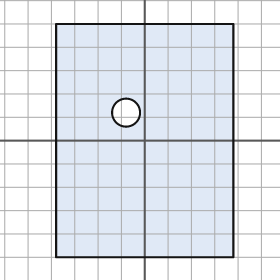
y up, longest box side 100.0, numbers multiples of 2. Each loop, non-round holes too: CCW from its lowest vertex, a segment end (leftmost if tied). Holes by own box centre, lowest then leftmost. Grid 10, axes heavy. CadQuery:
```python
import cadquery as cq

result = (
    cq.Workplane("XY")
    .moveTo(-38.0, -50.0)
    .lineTo(38.0, -50.0)
    .lineTo(38.0, 50.0)
    .lineTo(-38.0, 50.0)
    .close()
    .moveTo(-8.0, 12.0)
    .circle(6.0)
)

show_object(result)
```